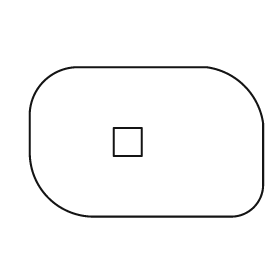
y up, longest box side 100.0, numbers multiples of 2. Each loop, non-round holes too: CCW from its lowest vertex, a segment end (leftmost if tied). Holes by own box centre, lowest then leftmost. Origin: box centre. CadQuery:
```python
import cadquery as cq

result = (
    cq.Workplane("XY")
    .moveTo(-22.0, -32.0)
    .lineTo(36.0, -32.0)
    .threePointArc((46.0, -28.0), (50.0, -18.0))
    .lineTo(50.0, 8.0)
    .threePointArc((42.0, 24.0), (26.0, 32.0))
    .lineTo(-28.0, 32.0)
    .threePointArc((-44.0, 26.0), (-50.0, 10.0))
    .lineTo(-50.0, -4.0)
    .threePointArc((-42.0, -24.0), (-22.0, -32.0))
    .close()
    .moveTo(-14.0, -6.0)
    .lineTo(-2.0, -6.0)
    .lineTo(-2.0, 6.0)
    .lineTo(-14.0, 6.0)
    .close()
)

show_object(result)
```